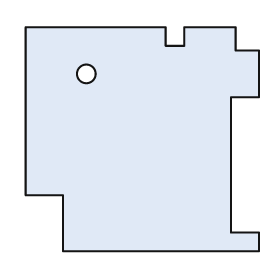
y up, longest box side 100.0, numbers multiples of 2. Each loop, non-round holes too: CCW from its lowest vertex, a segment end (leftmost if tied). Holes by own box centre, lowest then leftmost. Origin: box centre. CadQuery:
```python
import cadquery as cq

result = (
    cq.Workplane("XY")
    .moveTo(-34.0, -48.0)
    .lineTo(50.0, -48.0)
    .lineTo(50.0, -40.0)
    .lineTo(38.0, -40.0)
    .lineTo(38.0, 18.0)
    .lineTo(50.0, 18.0)
    .lineTo(50.0, 38.0)
    .lineTo(40.0, 38.0)
    .lineTo(40.0, 48.0)
    .lineTo(18.0, 48.0)
    .lineTo(18.0, 40.0)
    .lineTo(10.0, 40.0)
    .lineTo(10.0, 48.0)
    .lineTo(-50.0, 48.0)
    .lineTo(-50.0, -24.0)
    .lineTo(-34.0, -24.0)
    .close()
    .moveTo(-24.0, 28.0)
    .circle(4.0)
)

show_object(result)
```